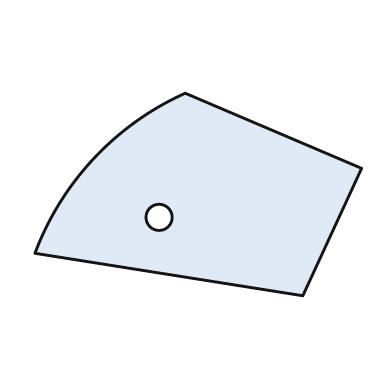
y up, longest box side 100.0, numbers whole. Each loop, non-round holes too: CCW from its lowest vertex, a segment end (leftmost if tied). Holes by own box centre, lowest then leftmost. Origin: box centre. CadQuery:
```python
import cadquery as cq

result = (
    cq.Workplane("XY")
    .moveTo(32.0, -31.0)
    .lineTo(50.0, 8.0)
    .lineTo(-4.0, 31.0)
    .threePointArc((-32.0, 11.0), (-50.0, -18.0))
    .close()
    .moveTo(-12.0, -7.0)
    .circle(4.0)
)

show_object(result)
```